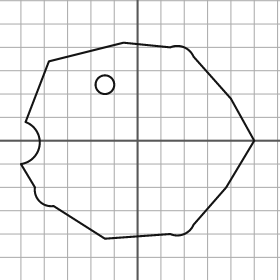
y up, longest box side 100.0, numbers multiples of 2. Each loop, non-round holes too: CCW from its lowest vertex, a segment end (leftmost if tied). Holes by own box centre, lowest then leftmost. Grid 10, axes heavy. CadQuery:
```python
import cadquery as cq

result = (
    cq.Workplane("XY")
    .moveTo(-14.0, -42.0)
    .lineTo(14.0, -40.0)
    .threePointArc((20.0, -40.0), (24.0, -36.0))
    .lineTo(38.0, -20.0)
    .lineTo(50.0, 0.0)
    .lineTo(40.0, 18.0)
    .lineTo(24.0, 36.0)
    .threePointArc((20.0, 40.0), (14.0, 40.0))
    .lineTo(-6.0, 42.0)
    .lineTo(-38.0, 34.0)
    .lineTo(-48.0, 8.0)
    .threePointArc((-42.0, -2.0), (-50.0, -10.0))
    .lineTo(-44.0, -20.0)
    .threePointArc((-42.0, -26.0), (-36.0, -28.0))
    .close()
    .moveTo(-14.0, 24.0)
    .circle(4.0)
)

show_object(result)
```